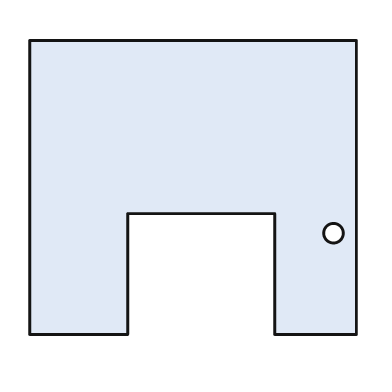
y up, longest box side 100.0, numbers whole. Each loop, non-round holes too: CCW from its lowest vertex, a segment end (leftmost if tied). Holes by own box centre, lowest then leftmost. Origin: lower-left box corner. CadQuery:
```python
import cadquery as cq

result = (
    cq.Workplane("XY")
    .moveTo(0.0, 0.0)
    .lineTo(30.0, 0.0)
    .lineTo(30.0, 37.0)
    .lineTo(75.0, 37.0)
    .lineTo(75.0, 0.0)
    .lineTo(100.0, 0.0)
    .lineTo(100.0, 90.0)
    .lineTo(0.0, 90.0)
    .close()
    .moveTo(93.0, 31.0)
    .circle(3.0)
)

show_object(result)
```